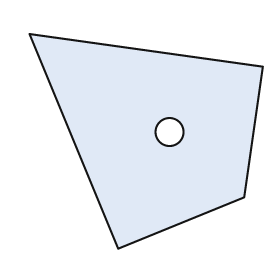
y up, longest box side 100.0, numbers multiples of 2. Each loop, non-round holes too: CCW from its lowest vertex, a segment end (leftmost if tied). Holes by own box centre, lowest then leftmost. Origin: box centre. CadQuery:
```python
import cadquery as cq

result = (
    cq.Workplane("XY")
    .moveTo(-12.0, -46.0)
    .lineTo(42.0, -24.0)
    .lineTo(50.0, 32.0)
    .lineTo(-50.0, 46.0)
    .close()
    .moveTo(10.0, 4.0)
    .circle(6.0)
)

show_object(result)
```